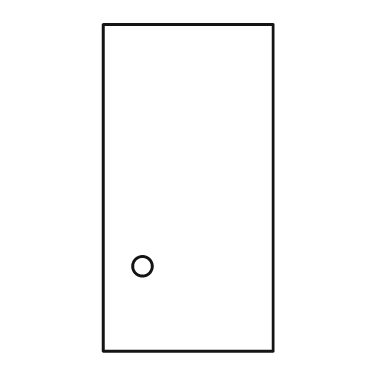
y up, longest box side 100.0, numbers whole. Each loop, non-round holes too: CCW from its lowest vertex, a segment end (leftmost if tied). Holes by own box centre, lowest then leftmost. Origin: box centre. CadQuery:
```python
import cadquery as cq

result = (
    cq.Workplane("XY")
    .moveTo(-26.0, -50.0)
    .lineTo(26.0, -50.0)
    .lineTo(26.0, 50.0)
    .lineTo(-26.0, 50.0)
    .close()
    .moveTo(-14.0, -24.0)
    .circle(3.0)
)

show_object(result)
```